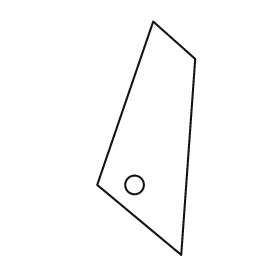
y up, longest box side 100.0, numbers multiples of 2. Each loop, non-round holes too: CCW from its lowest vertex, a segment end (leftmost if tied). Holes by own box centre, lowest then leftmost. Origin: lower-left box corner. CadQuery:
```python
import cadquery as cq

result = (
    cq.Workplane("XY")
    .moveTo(36.0, 0.0)
    .lineTo(42.0, 84.0)
    .lineTo(24.0, 100.0)
    .lineTo(0.0, 30.0)
    .close()
    .moveTo(16.0, 30.0)
    .circle(4.0)
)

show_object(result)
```